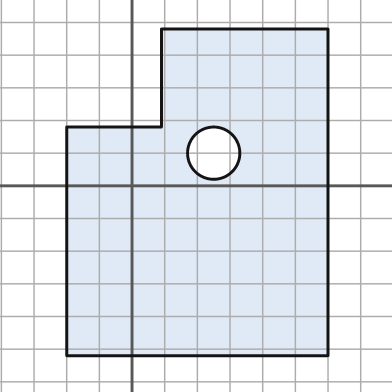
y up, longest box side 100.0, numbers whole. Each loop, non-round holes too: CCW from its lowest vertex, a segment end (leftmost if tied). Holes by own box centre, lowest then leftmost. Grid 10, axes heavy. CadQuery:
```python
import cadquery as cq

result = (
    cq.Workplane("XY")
    .moveTo(-20.0, -52.0)
    .lineTo(60.0, -52.0)
    .lineTo(60.0, 48.0)
    .lineTo(9.0, 48.0)
    .lineTo(9.0, 18.0)
    .lineTo(-20.0, 18.0)
    .close()
    .moveTo(25.0, 10.0)
    .circle(8.0)
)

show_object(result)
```